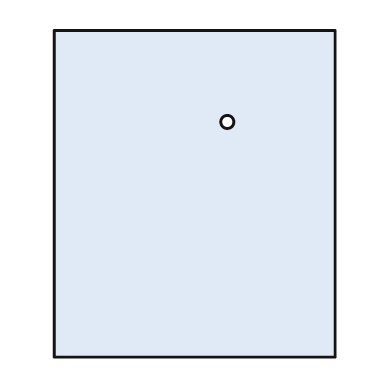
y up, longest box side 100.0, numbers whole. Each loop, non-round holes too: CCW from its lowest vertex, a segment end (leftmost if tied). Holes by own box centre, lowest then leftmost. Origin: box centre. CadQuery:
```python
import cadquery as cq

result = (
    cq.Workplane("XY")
    .moveTo(-43.0, -50.0)
    .lineTo(43.0, -50.0)
    .lineTo(43.0, 50.0)
    .lineTo(-43.0, 50.0)
    .close()
    .moveTo(10.0, 22.0)
    .circle(2.0)
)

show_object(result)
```